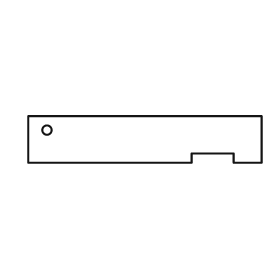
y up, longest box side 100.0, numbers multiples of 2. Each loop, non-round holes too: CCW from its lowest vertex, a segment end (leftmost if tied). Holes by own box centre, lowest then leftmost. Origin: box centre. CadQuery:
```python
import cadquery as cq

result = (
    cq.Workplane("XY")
    .moveTo(-50.0, -10.0)
    .lineTo(20.0, -10.0)
    .lineTo(20.0, -6.0)
    .lineTo(38.0, -6.0)
    .lineTo(38.0, -10.0)
    .lineTo(50.0, -10.0)
    .lineTo(50.0, 10.0)
    .lineTo(-50.0, 10.0)
    .close()
    .moveTo(-42.0, 4.0)
    .circle(2.0)
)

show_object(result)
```